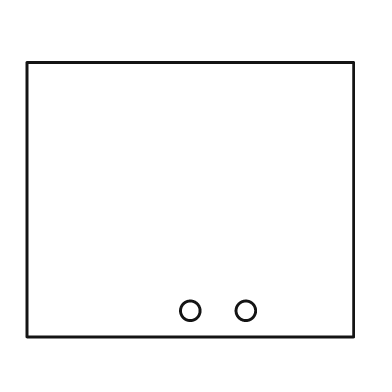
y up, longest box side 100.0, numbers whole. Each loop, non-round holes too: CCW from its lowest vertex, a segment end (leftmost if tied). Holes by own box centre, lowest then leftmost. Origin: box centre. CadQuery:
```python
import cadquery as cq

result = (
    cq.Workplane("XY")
    .moveTo(-50.0, -42.0)
    .lineTo(50.0, -42.0)
    .lineTo(50.0, 42.0)
    .lineTo(-50.0, 42.0)
    .close()
    .moveTo(0.0, -34.0)
    .circle(3.0)
    .moveTo(17.0, -34.0)
    .circle(3.0)
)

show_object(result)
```